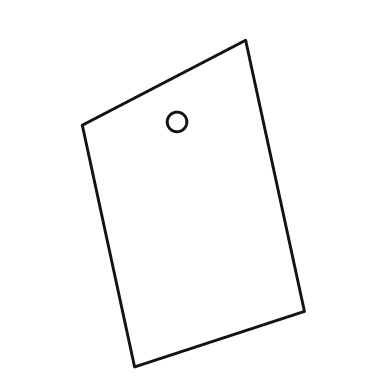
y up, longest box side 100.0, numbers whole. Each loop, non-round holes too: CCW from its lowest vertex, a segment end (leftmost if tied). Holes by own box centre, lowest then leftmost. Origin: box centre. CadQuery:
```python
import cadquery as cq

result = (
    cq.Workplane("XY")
    .moveTo(-18.0, -50.0)
    .lineTo(34.0, -33.0)
    .lineTo(16.0, 50.0)
    .lineTo(-34.0, 24.0)
    .close()
    .moveTo(-5.0, 25.0)
    .circle(3.0)
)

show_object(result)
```